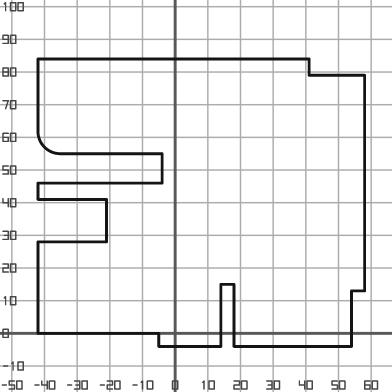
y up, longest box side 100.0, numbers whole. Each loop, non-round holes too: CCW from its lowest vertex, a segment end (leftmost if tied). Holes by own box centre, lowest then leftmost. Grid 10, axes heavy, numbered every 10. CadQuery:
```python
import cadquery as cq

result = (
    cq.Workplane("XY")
    .moveTo(-5.0, -4.0)
    .lineTo(14.0, -4.0)
    .lineTo(14.0, 15.0)
    .lineTo(18.0, 15.0)
    .lineTo(18.0, -4.0)
    .lineTo(54.0, -4.0)
    .lineTo(54.0, 13.0)
    .lineTo(58.0, 13.0)
    .lineTo(58.0, 79.0)
    .lineTo(41.0, 79.0)
    .lineTo(41.0, 84.0)
    .lineTo(-42.0, 84.0)
    .lineTo(-42.0, 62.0)
    .threePointArc((-40.0, 57.0), (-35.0, 55.0))
    .lineTo(-4.0, 55.0)
    .lineTo(-4.0, 46.0)
    .lineTo(-42.0, 46.0)
    .lineTo(-42.0, 41.0)
    .lineTo(-21.0, 41.0)
    .lineTo(-21.0, 28.0)
    .lineTo(-42.0, 28.0)
    .lineTo(-42.0, 0.0)
    .lineTo(-5.0, 0.0)
    .close()
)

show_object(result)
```